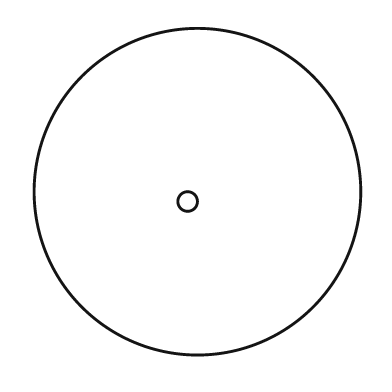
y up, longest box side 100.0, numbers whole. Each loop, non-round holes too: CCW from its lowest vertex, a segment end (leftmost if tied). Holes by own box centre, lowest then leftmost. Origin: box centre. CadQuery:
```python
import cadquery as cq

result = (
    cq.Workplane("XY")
    .moveTo(0.0, 0.0)
    .circle(50.0)
    .moveTo(-3.0, -3.0)
    .circle(3.0)
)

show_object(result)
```